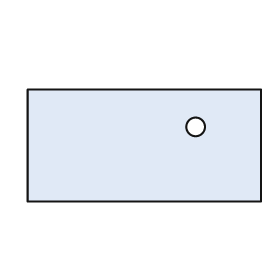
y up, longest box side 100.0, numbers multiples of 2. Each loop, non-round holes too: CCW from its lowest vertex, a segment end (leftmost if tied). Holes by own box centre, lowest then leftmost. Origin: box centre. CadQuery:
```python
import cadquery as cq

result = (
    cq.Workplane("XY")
    .moveTo(-50.0, -24.0)
    .lineTo(50.0, -24.0)
    .lineTo(50.0, 24.0)
    .lineTo(-50.0, 24.0)
    .close()
    .moveTo(22.0, 8.0)
    .circle(4.0)
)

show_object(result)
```